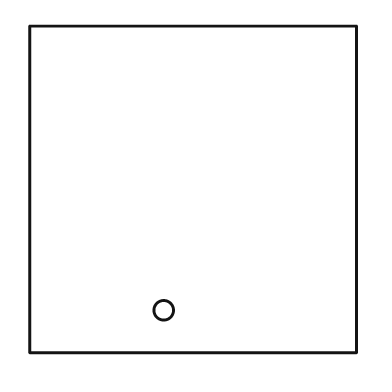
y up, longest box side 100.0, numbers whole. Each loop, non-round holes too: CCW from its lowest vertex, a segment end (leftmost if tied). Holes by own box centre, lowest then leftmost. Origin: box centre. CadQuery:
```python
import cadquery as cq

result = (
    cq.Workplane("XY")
    .moveTo(-50.0, -50.0)
    .lineTo(50.0, -50.0)
    .lineTo(50.0, 50.0)
    .lineTo(-50.0, 50.0)
    .close()
    .moveTo(-9.0, -37.0)
    .circle(3.0)
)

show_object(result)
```